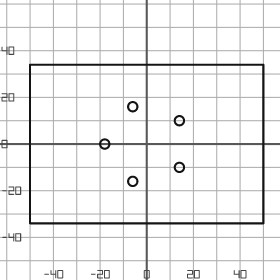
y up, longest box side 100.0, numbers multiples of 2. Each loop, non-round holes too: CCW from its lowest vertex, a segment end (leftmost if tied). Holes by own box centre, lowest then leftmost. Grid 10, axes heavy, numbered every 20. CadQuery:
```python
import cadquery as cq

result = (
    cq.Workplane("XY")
    .moveTo(-50.0, -34.0)
    .lineTo(50.0, -34.0)
    .lineTo(50.0, 34.0)
    .lineTo(-50.0, 34.0)
    .close()
    .moveTo(-6.0, -16.0)
    .circle(2.0)
    .moveTo(14.0, -10.0)
    .circle(2.0)
    .moveTo(-18.0, 0.0)
    .circle(2.0)
    .moveTo(14.0, 10.0)
    .circle(2.0)
    .moveTo(-6.0, 16.0)
    .circle(2.0)
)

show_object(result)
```